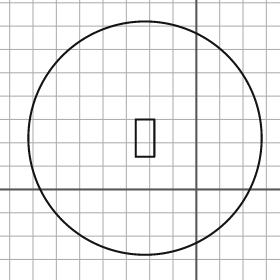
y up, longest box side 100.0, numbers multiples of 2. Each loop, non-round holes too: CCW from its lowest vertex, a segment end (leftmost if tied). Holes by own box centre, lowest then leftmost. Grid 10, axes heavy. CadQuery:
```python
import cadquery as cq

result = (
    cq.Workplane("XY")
    .moveTo(-22.0, 22.0)
    .circle(50.0)
    .moveTo(-26.0, 14.0)
    .lineTo(-18.0, 14.0)
    .lineTo(-18.0, 30.0)
    .lineTo(-26.0, 30.0)
    .close()
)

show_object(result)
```